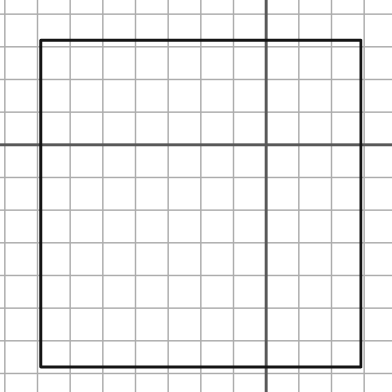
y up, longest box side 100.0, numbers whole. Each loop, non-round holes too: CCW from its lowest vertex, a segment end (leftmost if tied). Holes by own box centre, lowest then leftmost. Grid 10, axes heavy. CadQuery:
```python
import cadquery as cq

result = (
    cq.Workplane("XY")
    .moveTo(-69.0, -68.0)
    .lineTo(29.0, -68.0)
    .lineTo(29.0, 32.0)
    .lineTo(-69.0, 32.0)
    .close()
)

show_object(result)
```